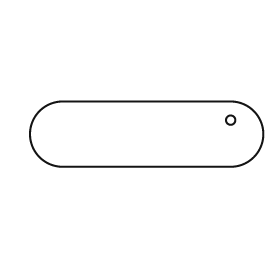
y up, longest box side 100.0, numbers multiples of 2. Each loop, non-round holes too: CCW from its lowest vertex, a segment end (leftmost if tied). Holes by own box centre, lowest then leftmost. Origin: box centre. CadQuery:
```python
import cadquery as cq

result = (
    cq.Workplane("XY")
    .moveTo(-36.0, -14.0)
    .lineTo(36.0, -14.0)
    .threePointArc((50.0, 0.0), (36.0, 14.0))
    .lineTo(-36.0, 14.0)
    .threePointArc((-50.0, 0.0), (-36.0, -14.0))
    .close()
    .moveTo(36.0, 6.0)
    .circle(2.0)
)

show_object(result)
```